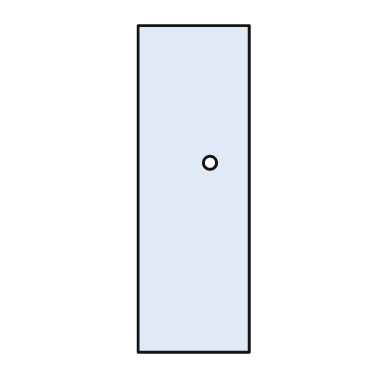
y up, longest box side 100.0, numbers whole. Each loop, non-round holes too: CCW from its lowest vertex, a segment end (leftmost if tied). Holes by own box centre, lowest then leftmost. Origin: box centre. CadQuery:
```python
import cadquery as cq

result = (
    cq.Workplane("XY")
    .moveTo(-17.0, -50.0)
    .lineTo(17.0, -50.0)
    .lineTo(17.0, 50.0)
    .lineTo(-17.0, 50.0)
    .close()
    .moveTo(5.0, 8.0)
    .circle(2.0)
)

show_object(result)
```